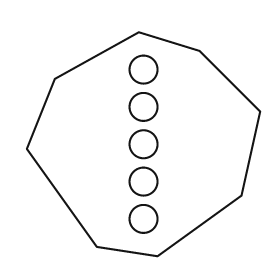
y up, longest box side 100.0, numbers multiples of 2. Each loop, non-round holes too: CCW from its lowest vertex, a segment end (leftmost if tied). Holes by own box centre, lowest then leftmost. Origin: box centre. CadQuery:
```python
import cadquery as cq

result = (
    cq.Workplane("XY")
    .moveTo(6.0, -48.0)
    .lineTo(42.0, -22.0)
    .lineTo(50.0, 14.0)
    .lineTo(24.0, 40.0)
    .lineTo(-2.0, 48.0)
    .lineTo(-38.0, 28.0)
    .lineTo(-50.0, -2.0)
    .lineTo(-20.0, -44.0)
    .close()
    .moveTo(0.0, -32.0)
    .circle(6.0)
    .moveTo(0.0, -16.0)
    .circle(6.0)
    .moveTo(0.0, 0.0)
    .circle(6.0)
    .moveTo(0.0, 16.0)
    .circle(6.0)
    .moveTo(0.0, 32.0)
    .circle(6.0)
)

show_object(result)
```